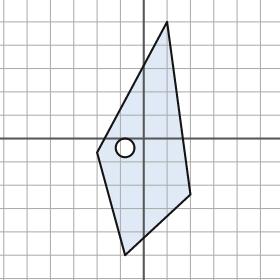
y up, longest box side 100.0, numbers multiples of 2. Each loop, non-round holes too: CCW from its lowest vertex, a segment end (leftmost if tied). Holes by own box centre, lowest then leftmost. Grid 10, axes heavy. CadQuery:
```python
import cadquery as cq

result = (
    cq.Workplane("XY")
    .moveTo(-8.0, -50.0)
    .lineTo(20.0, -24.0)
    .lineTo(10.0, 50.0)
    .lineTo(-20.0, -6.0)
    .close()
    .moveTo(-8.0, -4.0)
    .circle(4.0)
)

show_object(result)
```